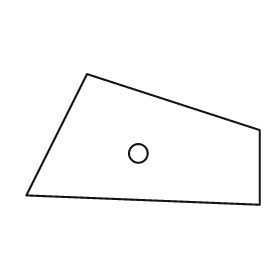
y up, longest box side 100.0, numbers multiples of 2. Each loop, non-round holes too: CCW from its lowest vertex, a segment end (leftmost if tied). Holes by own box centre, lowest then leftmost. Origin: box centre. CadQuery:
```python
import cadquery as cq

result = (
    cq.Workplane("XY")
    .moveTo(50.0, -28.0)
    .lineTo(50.0, 4.0)
    .lineTo(-24.0, 28.0)
    .lineTo(-50.0, -24.0)
    .close()
    .moveTo(-2.0, -6.0)
    .circle(4.0)
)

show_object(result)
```